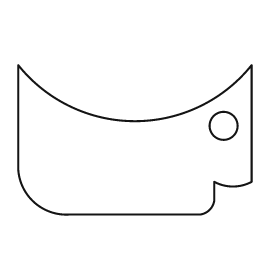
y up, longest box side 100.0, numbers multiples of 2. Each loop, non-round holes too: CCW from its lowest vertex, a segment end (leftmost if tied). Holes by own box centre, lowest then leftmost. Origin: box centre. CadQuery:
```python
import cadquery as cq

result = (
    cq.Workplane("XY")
    .moveTo(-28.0, -32.0)
    .lineTo(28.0, -32.0)
    .threePointArc((32.0, -30.0), (34.0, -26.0))
    .lineTo(34.0, -18.0)
    .threePointArc((42.0, -20.0), (50.0, -18.0))
    .lineTo(50.0, 32.0)
    .threePointArc((0.0, 8.0), (-50.0, 32.0))
    .lineTo(-50.0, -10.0)
    .threePointArc((-44.0, -26.0), (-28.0, -32.0))
    .close()
    .moveTo(38.0, 6.0)
    .circle(6.0)
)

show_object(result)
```